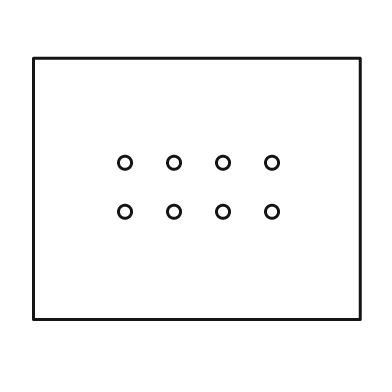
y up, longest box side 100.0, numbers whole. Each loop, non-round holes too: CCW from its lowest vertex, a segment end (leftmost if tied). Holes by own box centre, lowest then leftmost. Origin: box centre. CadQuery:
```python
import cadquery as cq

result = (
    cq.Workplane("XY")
    .moveTo(-50.0, -40.0)
    .lineTo(50.0, -40.0)
    .lineTo(50.0, 40.0)
    .lineTo(-50.0, 40.0)
    .close()
    .moveTo(-22.0, -7.0)
    .circle(2.0)
    .moveTo(-7.0, -7.0)
    .circle(2.0)
    .moveTo(8.0, -7.0)
    .circle(2.0)
    .moveTo(23.0, -7.0)
    .circle(2.0)
    .moveTo(-22.0, 8.0)
    .circle(2.0)
    .moveTo(-7.0, 8.0)
    .circle(2.0)
    .moveTo(8.0, 8.0)
    .circle(2.0)
    .moveTo(23.0, 8.0)
    .circle(2.0)
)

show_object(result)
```